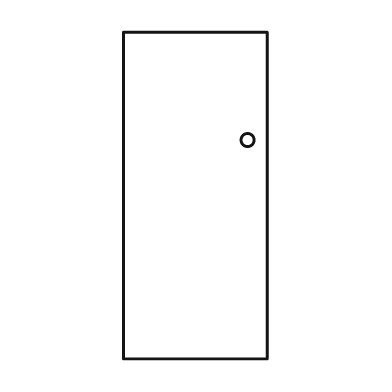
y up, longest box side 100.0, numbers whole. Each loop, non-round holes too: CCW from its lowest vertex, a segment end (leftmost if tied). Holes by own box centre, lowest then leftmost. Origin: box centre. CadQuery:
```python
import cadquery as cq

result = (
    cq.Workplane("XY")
    .moveTo(-22.0, -50.0)
    .lineTo(22.0, -50.0)
    .lineTo(22.0, 50.0)
    .lineTo(-22.0, 50.0)
    .close()
    .moveTo(16.0, 17.0)
    .circle(2.0)
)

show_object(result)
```